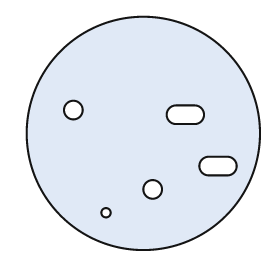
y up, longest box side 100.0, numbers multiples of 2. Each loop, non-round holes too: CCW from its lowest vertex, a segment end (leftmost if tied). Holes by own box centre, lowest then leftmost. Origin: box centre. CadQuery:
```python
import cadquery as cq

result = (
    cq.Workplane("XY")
    .moveTo(0.0, 0.0)
    .circle(50.0)
    .moveTo(-16.0, -34.0)
    .circle(2.0)
    .moveTo(4.0, -24.0)
    .circle(4.0)
    .moveTo(28.0, -18.0)
    .lineTo(36.0, -18.0)
    .threePointArc((40.0, -14.0), (36.0, -10.0))
    .lineTo(28.0, -10.0)
    .threePointArc((24.0, -14.0), (28.0, -18.0))
    .close()
    .moveTo(14.0, 4.0)
    .lineTo(22.0, 4.0)
    .threePointArc((26.0, 8.0), (22.0, 12.0))
    .lineTo(14.0, 12.0)
    .threePointArc((10.0, 8.0), (14.0, 4.0))
    .close()
    .moveTo(-30.0, 10.0)
    .circle(4.0)
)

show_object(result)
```